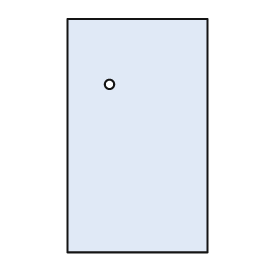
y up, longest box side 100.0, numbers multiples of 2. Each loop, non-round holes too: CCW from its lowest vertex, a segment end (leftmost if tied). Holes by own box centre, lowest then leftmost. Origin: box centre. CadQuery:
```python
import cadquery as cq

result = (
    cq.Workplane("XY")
    .moveTo(-30.0, -50.0)
    .lineTo(30.0, -50.0)
    .lineTo(30.0, 50.0)
    .lineTo(-30.0, 50.0)
    .close()
    .moveTo(-12.0, 22.0)
    .circle(2.0)
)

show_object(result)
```